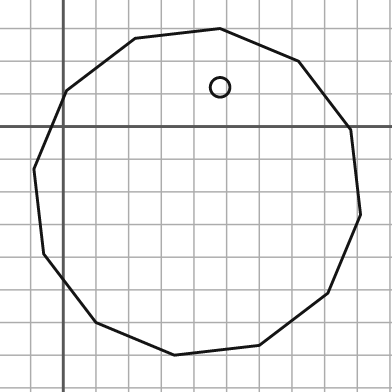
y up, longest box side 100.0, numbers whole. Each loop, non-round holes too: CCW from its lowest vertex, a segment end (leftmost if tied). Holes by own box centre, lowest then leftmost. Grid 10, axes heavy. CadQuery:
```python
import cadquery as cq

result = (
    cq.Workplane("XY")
    .moveTo(34.0, -70.0)
    .lineTo(60.0, -67.0)
    .lineTo(81.0, -51.0)
    .lineTo(91.0, -27.0)
    .lineTo(88.0, -1.0)
    .lineTo(72.0, 20.0)
    .lineTo(48.0, 30.0)
    .lineTo(22.0, 27.0)
    .lineTo(1.0, 11.0)
    .lineTo(-9.0, -13.0)
    .lineTo(-6.0, -39.0)
    .lineTo(10.0, -60.0)
    .close()
    .moveTo(48.0, 12.0)
    .circle(3.0)
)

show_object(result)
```